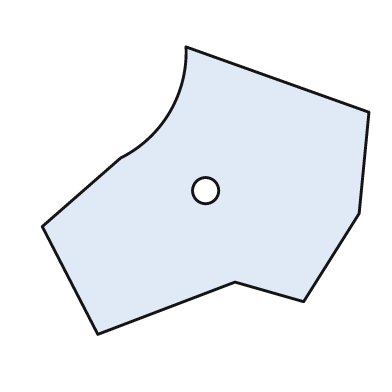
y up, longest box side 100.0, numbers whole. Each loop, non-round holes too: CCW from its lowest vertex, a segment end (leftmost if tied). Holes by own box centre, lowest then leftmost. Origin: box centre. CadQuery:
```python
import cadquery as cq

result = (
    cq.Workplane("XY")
    .moveTo(-33.0, -44.0)
    .lineTo(9.0, -28.0)
    .lineTo(30.0, -34.0)
    .lineTo(47.0, -7.0)
    .lineTo(50.0, 24.0)
    .lineTo(-6.0, 44.0)
    .threePointArc((-11.0, 24.0), (-26.0, 10.0))
    .lineTo(-50.0, -11.0)
    .close()
    .moveTo(0.0, 0.0)
    .circle(4.0)
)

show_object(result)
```